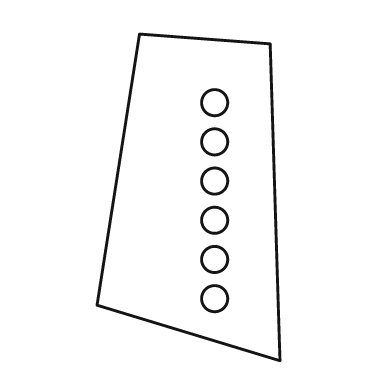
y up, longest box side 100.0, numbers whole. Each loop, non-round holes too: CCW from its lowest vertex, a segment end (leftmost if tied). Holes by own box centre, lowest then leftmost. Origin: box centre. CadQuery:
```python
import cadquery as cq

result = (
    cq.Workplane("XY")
    .moveTo(28.0, -50.0)
    .lineTo(25.0, 47.0)
    .lineTo(-15.0, 50.0)
    .lineTo(-28.0, -33.0)
    .close()
    .moveTo(8.0, -31.0)
    .circle(4.0)
    .moveTo(8.0, -19.0)
    .circle(4.0)
    .moveTo(8.0, -7.0)
    .circle(4.0)
    .moveTo(8.0, 5.0)
    .circle(4.0)
    .moveTo(8.0, 17.0)
    .circle(4.0)
    .moveTo(8.0, 29.0)
    .circle(4.0)
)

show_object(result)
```